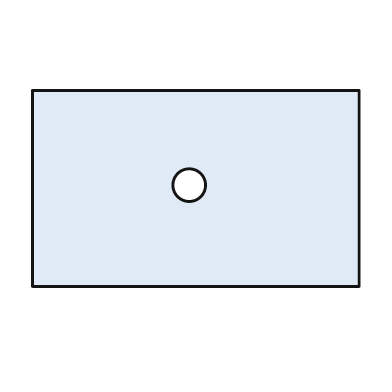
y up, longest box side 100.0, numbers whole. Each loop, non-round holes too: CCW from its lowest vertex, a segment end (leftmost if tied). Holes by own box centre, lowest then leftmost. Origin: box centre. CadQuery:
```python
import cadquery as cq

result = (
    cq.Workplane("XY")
    .moveTo(-50.0, -30.0)
    .lineTo(50.0, -30.0)
    .lineTo(50.0, 30.0)
    .lineTo(-50.0, 30.0)
    .close()
    .moveTo(-2.0, 1.0)
    .circle(5.0)
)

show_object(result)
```